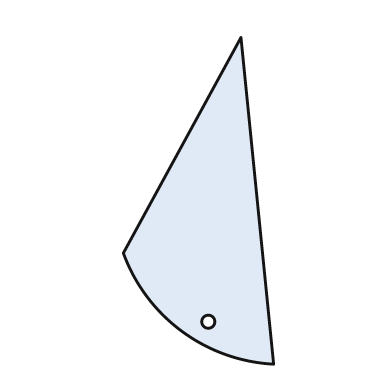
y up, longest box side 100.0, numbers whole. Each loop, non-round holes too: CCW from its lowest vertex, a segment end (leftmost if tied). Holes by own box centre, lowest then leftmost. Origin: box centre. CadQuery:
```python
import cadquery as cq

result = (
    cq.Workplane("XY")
    .moveTo(23.0, -50.0)
    .lineTo(13.0, 50.0)
    .lineTo(-23.0, -16.0)
    .threePointArc((-5.0, -40.0), (23.0, -50.0))
    .close()
    .moveTo(3.0, -37.0)
    .circle(2.0)
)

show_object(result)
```